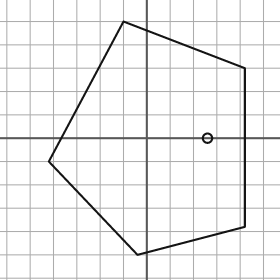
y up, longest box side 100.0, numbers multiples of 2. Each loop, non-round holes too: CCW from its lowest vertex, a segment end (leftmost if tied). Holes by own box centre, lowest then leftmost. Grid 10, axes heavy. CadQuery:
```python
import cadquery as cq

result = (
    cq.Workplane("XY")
    .moveTo(-4.0, -50.0)
    .lineTo(42.0, -38.0)
    .lineTo(42.0, 30.0)
    .lineTo(-10.0, 50.0)
    .lineTo(-42.0, -10.0)
    .close()
    .moveTo(26.0, 0.0)
    .circle(2.0)
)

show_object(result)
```